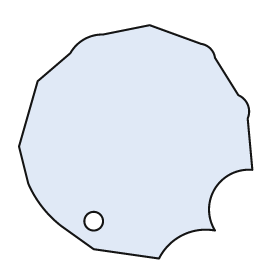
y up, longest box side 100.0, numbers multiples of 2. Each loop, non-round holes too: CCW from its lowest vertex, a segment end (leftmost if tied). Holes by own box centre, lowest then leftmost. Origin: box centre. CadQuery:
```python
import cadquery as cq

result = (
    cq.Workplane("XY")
    .moveTo(10.0, -50.0)
    .threePointArc((20.0, -40.0), (34.0, -38.0))
    .threePointArc((34.0, -20.0), (50.0, -12.0))
    .lineTo(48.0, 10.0)
    .threePointArc((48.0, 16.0), (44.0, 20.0))
    .lineTo(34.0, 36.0)
    .threePointArc((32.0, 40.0), (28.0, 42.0))
    .lineTo(6.0, 50.0)
    .lineTo(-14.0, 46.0)
    .threePointArc((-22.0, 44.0), (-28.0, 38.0))
    .lineTo(-42.0, 26.0)
    .lineTo(-50.0, -2.0)
    .lineTo(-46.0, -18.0)
    .threePointArc((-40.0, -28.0), (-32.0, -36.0))
    .lineTo(-18.0, -46.0)
    .close()
    .moveTo(-18.0, -34.0)
    .circle(4.0)
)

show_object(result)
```